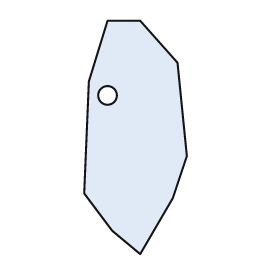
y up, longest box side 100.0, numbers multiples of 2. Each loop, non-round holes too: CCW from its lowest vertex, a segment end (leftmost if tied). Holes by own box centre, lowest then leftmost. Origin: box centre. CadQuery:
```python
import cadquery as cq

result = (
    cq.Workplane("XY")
    .moveTo(2.0, -50.0)
    .lineTo(16.0, -26.0)
    .lineTo(22.0, -8.0)
    .lineTo(18.0, 32.0)
    .lineTo(2.0, 50.0)
    .lineTo(-12.0, 50.0)
    .lineTo(-20.0, 24.0)
    .lineTo(-22.0, -24.0)
    .lineTo(-10.0, -40.0)
    .close()
    .moveTo(-12.0, 18.0)
    .circle(4.0)
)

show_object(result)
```